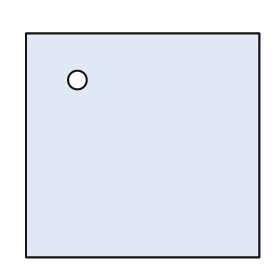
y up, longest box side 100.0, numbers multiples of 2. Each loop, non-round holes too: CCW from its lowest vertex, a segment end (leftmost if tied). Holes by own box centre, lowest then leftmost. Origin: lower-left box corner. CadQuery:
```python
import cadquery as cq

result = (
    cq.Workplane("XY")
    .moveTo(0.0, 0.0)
    .lineTo(100.0, 0.0)
    .lineTo(100.0, 96.0)
    .lineTo(0.0, 96.0)
    .close()
    .moveTo(22.0, 76.0)
    .circle(4.0)
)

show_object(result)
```